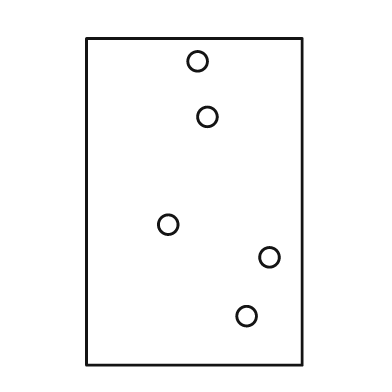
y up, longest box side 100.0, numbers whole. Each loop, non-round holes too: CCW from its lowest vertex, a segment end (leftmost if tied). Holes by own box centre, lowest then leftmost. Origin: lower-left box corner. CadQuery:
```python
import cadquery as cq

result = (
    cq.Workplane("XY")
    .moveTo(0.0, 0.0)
    .lineTo(66.0, 0.0)
    .lineTo(66.0, 100.0)
    .lineTo(0.0, 100.0)
    .close()
    .moveTo(49.0, 15.0)
    .circle(3.0)
    .moveTo(56.0, 33.0)
    .circle(3.0)
    .moveTo(25.0, 43.0)
    .circle(3.0)
    .moveTo(37.0, 76.0)
    .circle(3.0)
    .moveTo(34.0, 93.0)
    .circle(3.0)
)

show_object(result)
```